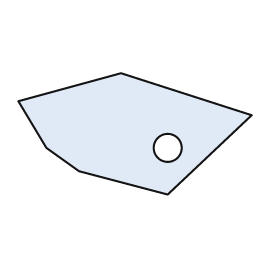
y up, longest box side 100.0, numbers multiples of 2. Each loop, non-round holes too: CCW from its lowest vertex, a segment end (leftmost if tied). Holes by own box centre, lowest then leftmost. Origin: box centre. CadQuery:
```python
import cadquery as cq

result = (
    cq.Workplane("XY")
    .moveTo(14.0, -26.0)
    .lineTo(50.0, 8.0)
    .lineTo(-6.0, 26.0)
    .lineTo(-50.0, 14.0)
    .lineTo(-38.0, -6.0)
    .lineTo(-24.0, -16.0)
    .close()
    .moveTo(14.0, -6.0)
    .circle(6.0)
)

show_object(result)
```